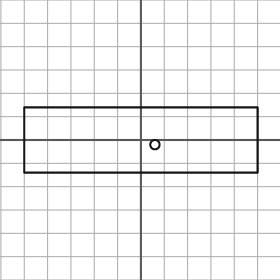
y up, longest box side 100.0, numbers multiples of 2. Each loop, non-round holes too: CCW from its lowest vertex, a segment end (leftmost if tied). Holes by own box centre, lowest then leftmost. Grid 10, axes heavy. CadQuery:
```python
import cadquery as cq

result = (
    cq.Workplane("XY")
    .moveTo(-50.0, -14.0)
    .lineTo(50.0, -14.0)
    .lineTo(50.0, 14.0)
    .lineTo(-50.0, 14.0)
    .close()
    .moveTo(6.0, -2.0)
    .circle(2.0)
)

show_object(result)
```